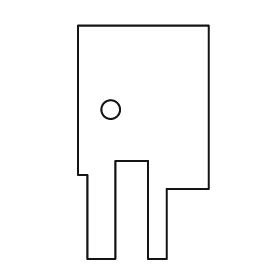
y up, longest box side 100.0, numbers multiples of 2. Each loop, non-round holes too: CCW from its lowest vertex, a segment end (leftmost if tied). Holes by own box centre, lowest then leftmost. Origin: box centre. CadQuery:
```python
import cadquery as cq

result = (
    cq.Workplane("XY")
    .moveTo(-24.0, -50.0)
    .lineTo(-12.0, -50.0)
    .lineTo(-12.0, -8.0)
    .lineTo(2.0, -8.0)
    .lineTo(2.0, -50.0)
    .lineTo(10.0, -50.0)
    .lineTo(10.0, -20.0)
    .lineTo(28.0, -20.0)
    .lineTo(28.0, 50.0)
    .lineTo(-28.0, 50.0)
    .lineTo(-28.0, -14.0)
    .lineTo(-24.0, -14.0)
    .close()
    .moveTo(-14.0, 14.0)
    .circle(4.0)
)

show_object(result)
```